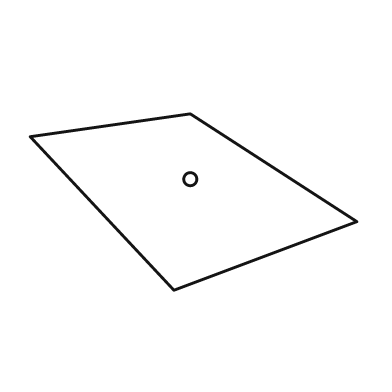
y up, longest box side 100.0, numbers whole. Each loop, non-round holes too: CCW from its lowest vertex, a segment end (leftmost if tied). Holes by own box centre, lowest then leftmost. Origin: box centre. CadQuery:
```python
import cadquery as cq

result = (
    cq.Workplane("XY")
    .moveTo(-6.0, -27.0)
    .lineTo(50.0, -6.0)
    .lineTo(-1.0, 27.0)
    .lineTo(-50.0, 20.0)
    .close()
    .moveTo(-1.0, 7.0)
    .circle(2.0)
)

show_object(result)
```